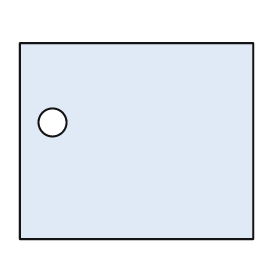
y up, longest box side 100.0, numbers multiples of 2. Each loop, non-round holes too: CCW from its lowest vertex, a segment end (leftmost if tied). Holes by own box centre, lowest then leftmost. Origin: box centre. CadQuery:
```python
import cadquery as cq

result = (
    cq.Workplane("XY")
    .moveTo(-50.0, -42.0)
    .lineTo(50.0, -42.0)
    .lineTo(50.0, 42.0)
    .lineTo(-50.0, 42.0)
    .close()
    .moveTo(-36.0, 8.0)
    .circle(6.0)
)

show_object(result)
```